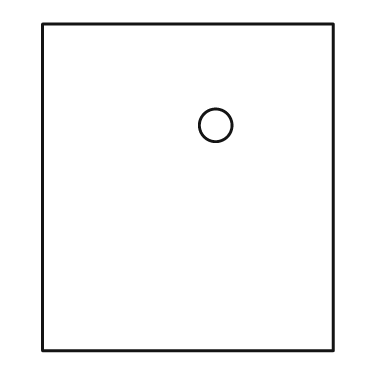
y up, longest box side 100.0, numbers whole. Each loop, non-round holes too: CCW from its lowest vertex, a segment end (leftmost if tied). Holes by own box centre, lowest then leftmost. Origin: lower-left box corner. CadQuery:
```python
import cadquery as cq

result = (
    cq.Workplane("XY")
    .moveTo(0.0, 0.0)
    .lineTo(89.0, 0.0)
    .lineTo(89.0, 100.0)
    .lineTo(0.0, 100.0)
    .close()
    .moveTo(53.0, 69.0)
    .circle(5.0)
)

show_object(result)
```